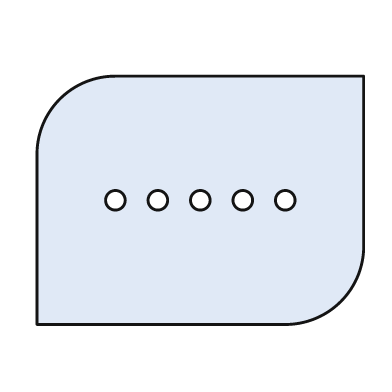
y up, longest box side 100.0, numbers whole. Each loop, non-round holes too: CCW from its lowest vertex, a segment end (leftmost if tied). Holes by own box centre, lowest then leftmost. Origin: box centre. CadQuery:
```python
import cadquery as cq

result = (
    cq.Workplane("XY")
    .moveTo(-50.0, -38.0)
    .lineTo(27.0, -38.0)
    .threePointArc((43.0, -31.0), (50.0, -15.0))
    .lineTo(50.0, 38.0)
    .lineTo(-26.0, 38.0)
    .threePointArc((-43.0, 31.0), (-50.0, 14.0))
    .close()
    .moveTo(-26.0, 0.0)
    .circle(3.0)
    .moveTo(-13.0, 0.0)
    .circle(3.0)
    .moveTo(0.0, 0.0)
    .circle(3.0)
    .moveTo(13.0, 0.0)
    .circle(3.0)
    .moveTo(26.0, 0.0)
    .circle(3.0)
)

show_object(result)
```